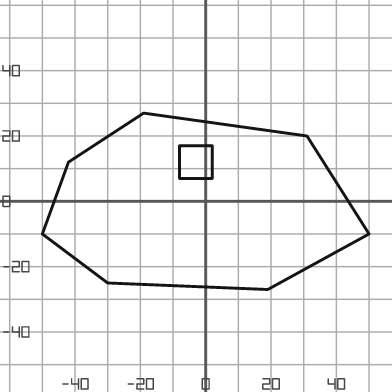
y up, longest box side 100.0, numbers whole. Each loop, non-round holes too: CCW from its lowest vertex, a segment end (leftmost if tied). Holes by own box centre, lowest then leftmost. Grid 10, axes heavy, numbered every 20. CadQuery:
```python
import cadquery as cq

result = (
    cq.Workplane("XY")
    .moveTo(19.0, -27.0)
    .lineTo(50.0, -10.0)
    .lineTo(31.0, 20.0)
    .lineTo(-19.0, 27.0)
    .lineTo(-42.0, 12.0)
    .lineTo(-50.0, -10.0)
    .lineTo(-30.0, -25.0)
    .close()
    .moveTo(-8.0, 7.0)
    .lineTo(2.0, 7.0)
    .lineTo(2.0, 17.0)
    .lineTo(-8.0, 17.0)
    .close()
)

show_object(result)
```